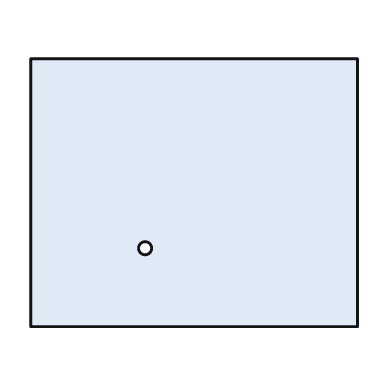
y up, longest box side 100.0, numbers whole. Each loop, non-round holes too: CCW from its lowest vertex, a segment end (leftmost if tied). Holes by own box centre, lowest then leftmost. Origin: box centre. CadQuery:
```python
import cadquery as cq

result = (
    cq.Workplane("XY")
    .moveTo(-50.0, -41.0)
    .lineTo(50.0, -41.0)
    .lineTo(50.0, 41.0)
    .lineTo(-50.0, 41.0)
    .close()
    .moveTo(-15.0, -17.0)
    .circle(2.0)
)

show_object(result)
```